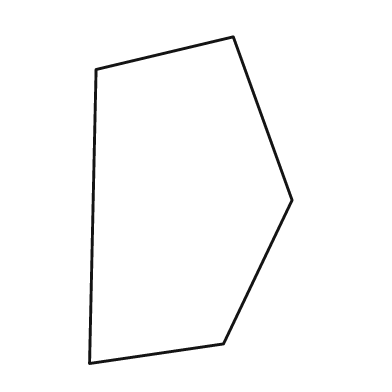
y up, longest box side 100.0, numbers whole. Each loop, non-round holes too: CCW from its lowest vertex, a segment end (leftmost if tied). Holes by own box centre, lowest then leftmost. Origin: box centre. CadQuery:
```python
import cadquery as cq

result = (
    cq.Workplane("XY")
    .moveTo(-31.0, -50.0)
    .lineTo(10.0, -44.0)
    .lineTo(31.0, 0.0)
    .lineTo(13.0, 50.0)
    .lineTo(-29.0, 40.0)
    .close()
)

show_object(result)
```